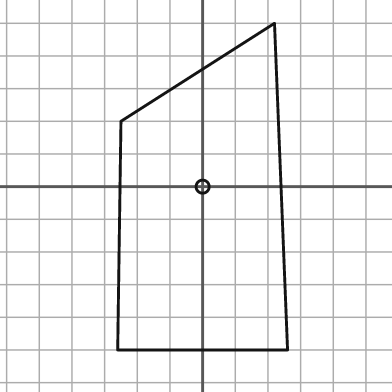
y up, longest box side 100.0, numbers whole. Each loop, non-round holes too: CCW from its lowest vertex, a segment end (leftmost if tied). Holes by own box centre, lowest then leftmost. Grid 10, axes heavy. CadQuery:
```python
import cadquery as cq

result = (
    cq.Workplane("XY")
    .moveTo(-26.0, -50.0)
    .lineTo(26.0, -50.0)
    .lineTo(22.0, 50.0)
    .lineTo(-25.0, 20.0)
    .close()
    .moveTo(0.0, 0.0)
    .circle(2.0)
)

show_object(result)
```